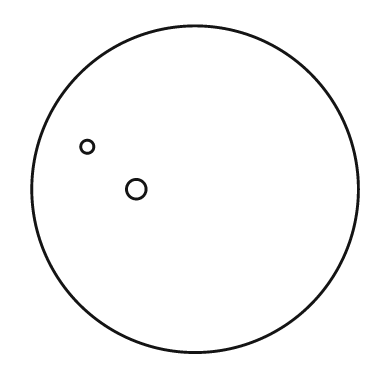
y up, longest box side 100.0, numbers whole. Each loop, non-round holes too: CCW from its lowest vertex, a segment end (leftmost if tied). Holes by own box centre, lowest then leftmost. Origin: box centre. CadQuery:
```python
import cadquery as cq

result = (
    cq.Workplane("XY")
    .moveTo(0.0, 0.0)
    .circle(50.0)
    .moveTo(-18.0, 0.0)
    .circle(3.0)
    .moveTo(-33.0, 13.0)
    .circle(2.0)
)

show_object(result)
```